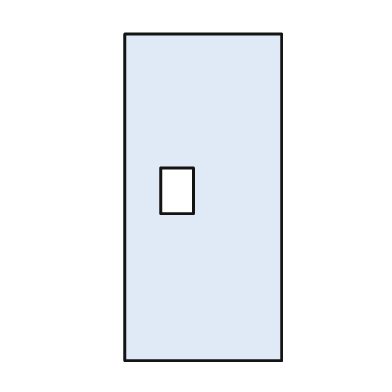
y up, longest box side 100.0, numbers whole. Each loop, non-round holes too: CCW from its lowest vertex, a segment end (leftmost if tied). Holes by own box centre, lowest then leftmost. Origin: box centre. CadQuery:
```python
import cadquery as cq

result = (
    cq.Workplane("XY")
    .moveTo(-24.0, -50.0)
    .lineTo(24.0, -50.0)
    .lineTo(24.0, 50.0)
    .lineTo(-24.0, 50.0)
    .close()
    .moveTo(-13.0, -5.0)
    .lineTo(-3.0, -5.0)
    .lineTo(-3.0, 9.0)
    .lineTo(-13.0, 9.0)
    .close()
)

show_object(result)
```